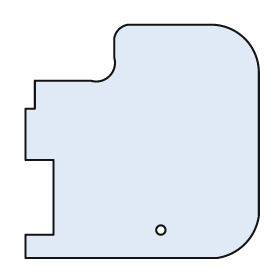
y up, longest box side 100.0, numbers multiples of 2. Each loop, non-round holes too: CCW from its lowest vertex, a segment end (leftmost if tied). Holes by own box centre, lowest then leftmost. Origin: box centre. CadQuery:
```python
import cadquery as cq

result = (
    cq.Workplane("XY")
    .moveTo(-50.0, -50.0)
    .lineTo(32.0, -50.0)
    .threePointArc((44.0, -44.0), (50.0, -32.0))
    .lineTo(50.0, 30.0)
    .threePointArc((44.0, 44.0), (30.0, 50.0))
    .lineTo(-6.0, 50.0)
    .threePointArc((-10.0, 48.0), (-12.0, 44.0))
    .lineTo(-12.0, 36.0)
    .threePointArc((-14.0, 28.0), (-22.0, 26.0))
    .lineTo(-46.0, 26.0)
    .lineTo(-46.0, 14.0)
    .lineTo(-50.0, 14.0)
    .lineTo(-50.0, -8.0)
    .lineTo(-38.0, -8.0)
    .lineTo(-38.0, -40.0)
    .lineTo(-50.0, -40.0)
    .close()
    .moveTo(8.0, -38.0)
    .circle(2.0)
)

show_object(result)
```